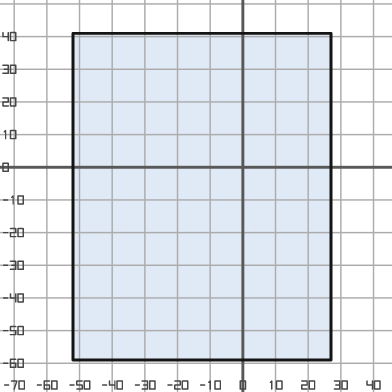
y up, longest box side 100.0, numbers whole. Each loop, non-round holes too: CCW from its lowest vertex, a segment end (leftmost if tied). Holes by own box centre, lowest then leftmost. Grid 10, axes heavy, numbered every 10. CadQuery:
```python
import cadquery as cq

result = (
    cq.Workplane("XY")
    .moveTo(-52.0, -59.0)
    .lineTo(27.0, -59.0)
    .lineTo(27.0, 41.0)
    .lineTo(-52.0, 41.0)
    .close()
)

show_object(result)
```